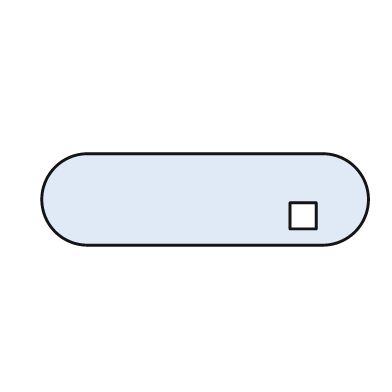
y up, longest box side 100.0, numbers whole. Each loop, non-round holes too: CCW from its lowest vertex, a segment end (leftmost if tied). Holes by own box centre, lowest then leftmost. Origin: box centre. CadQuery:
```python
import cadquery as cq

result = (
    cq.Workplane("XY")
    .moveTo(-36.0, -14.0)
    .lineTo(36.0, -14.0)
    .threePointArc((50.0, 0.0), (36.0, 14.0))
    .lineTo(-36.0, 14.0)
    .threePointArc((-50.0, 0.0), (-36.0, -14.0))
    .close()
    .moveTo(26.0, -9.0)
    .lineTo(34.0, -9.0)
    .lineTo(34.0, -1.0)
    .lineTo(26.0, -1.0)
    .close()
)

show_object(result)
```